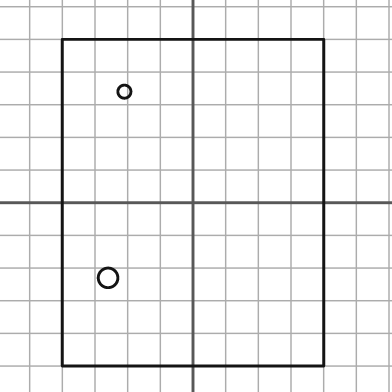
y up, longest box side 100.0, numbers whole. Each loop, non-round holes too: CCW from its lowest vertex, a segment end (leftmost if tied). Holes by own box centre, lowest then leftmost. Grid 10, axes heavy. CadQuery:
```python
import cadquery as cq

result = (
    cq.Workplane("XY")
    .moveTo(-40.0, -50.0)
    .lineTo(40.0, -50.0)
    .lineTo(40.0, 50.0)
    .lineTo(-40.0, 50.0)
    .close()
    .moveTo(-26.0, -23.0)
    .circle(3.0)
    .moveTo(-21.0, 34.0)
    .circle(2.0)
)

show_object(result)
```